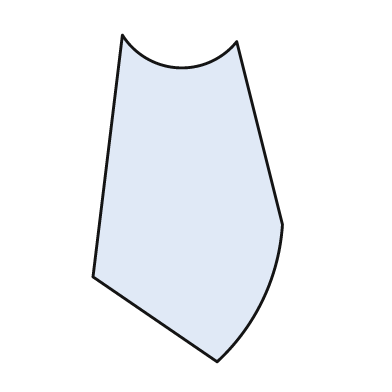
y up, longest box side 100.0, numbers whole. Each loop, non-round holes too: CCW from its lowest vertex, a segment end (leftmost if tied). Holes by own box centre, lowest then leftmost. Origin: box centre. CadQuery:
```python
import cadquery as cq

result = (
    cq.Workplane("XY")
    .moveTo(9.0, -50.0)
    .threePointArc((23.0, -31.0), (29.0, -8.0))
    .lineTo(15.0, 48.0)
    .threePointArc((-3.0, 40.0), (-20.0, 50.0))
    .lineTo(-29.0, -24.0)
    .close()
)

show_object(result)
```